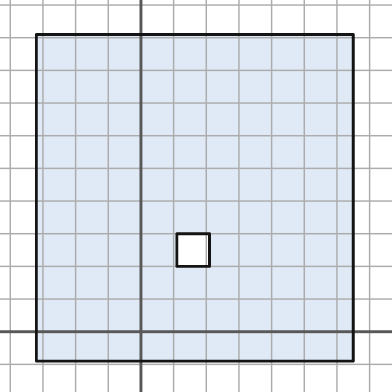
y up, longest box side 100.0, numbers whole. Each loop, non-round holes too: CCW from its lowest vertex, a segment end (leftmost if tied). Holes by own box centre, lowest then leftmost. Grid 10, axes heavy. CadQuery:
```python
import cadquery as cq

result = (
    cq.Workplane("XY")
    .moveTo(-32.0, -9.0)
    .lineTo(65.0, -9.0)
    .lineTo(65.0, 91.0)
    .lineTo(-32.0, 91.0)
    .close()
    .moveTo(11.0, 20.0)
    .lineTo(21.0, 20.0)
    .lineTo(21.0, 30.0)
    .lineTo(11.0, 30.0)
    .close()
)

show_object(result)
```